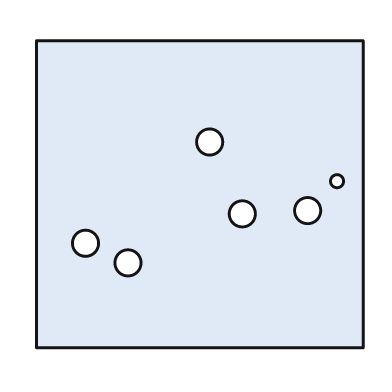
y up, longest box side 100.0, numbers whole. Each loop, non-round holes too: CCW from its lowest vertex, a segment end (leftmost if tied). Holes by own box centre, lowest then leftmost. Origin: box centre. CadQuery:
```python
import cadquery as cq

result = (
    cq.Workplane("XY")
    .moveTo(-50.0, -47.0)
    .lineTo(50.0, -47.0)
    .lineTo(50.0, 47.0)
    .lineTo(-50.0, 47.0)
    .close()
    .moveTo(-22.0, -21.0)
    .circle(4.0)
    .moveTo(-35.0, -15.0)
    .circle(4.0)
    .moveTo(13.0, -6.0)
    .circle(4.0)
    .moveTo(33.0, -5.0)
    .circle(4.0)
    .moveTo(42.0, 4.0)
    .circle(2.0)
    .moveTo(3.0, 16.0)
    .circle(4.0)
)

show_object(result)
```